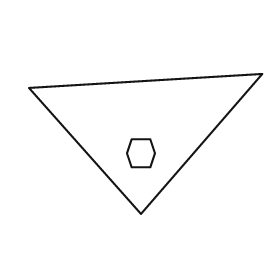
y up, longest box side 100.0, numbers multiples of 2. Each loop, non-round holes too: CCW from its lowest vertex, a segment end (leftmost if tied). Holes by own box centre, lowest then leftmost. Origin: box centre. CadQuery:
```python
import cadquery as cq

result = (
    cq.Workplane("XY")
    .moveTo(-2.0, -30.0)
    .lineTo(50.0, 30.0)
    .lineTo(-50.0, 24.0)
    .close()
    .moveTo(-6.0, -10.0)
    .lineTo(2.0, -10.0)
    .lineTo(4.0, -4.0)
    .lineTo(2.0, 2.0)
    .lineTo(-6.0, 2.0)
    .lineTo(-8.0, -4.0)
    .close()
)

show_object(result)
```